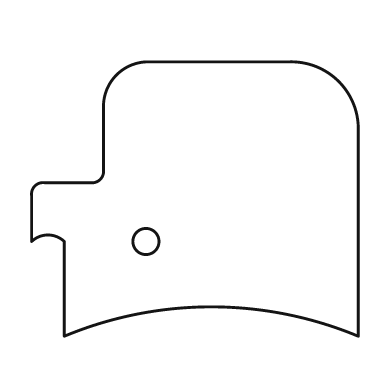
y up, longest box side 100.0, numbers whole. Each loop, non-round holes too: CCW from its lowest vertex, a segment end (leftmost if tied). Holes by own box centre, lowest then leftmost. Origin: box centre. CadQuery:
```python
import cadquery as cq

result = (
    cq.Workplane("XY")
    .moveTo(-40.0, -42.0)
    .threePointArc((5.0, -33.0), (50.0, -42.0))
    .lineTo(50.0, 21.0)
    .threePointArc((44.0, 36.0), (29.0, 42.0))
    .lineTo(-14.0, 42.0)
    .threePointArc((-24.0, 38.0), (-28.0, 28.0))
    .lineTo(-28.0, 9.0)
    .threePointArc((-29.0, 6.0), (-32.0, 5.0))
    .lineTo(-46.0, 5.0)
    .threePointArc((-49.0, 4.0), (-50.0, 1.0))
    .lineTo(-50.0, -13.0)
    .threePointArc((-45.0, -11.0), (-40.0, -13.0))
    .close()
    .moveTo(-15.0, -13.0)
    .circle(4.0)
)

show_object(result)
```